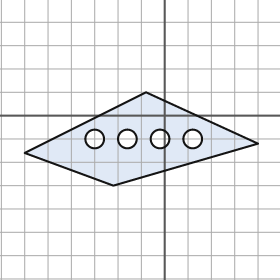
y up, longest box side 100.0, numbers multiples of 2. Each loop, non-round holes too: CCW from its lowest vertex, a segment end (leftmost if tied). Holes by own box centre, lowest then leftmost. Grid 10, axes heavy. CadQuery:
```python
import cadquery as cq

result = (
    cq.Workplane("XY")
    .moveTo(-22.0, -30.0)
    .lineTo(40.0, -12.0)
    .lineTo(-8.0, 10.0)
    .lineTo(-60.0, -16.0)
    .close()
    .moveTo(-30.0, -10.0)
    .circle(4.0)
    .moveTo(-16.0, -10.0)
    .circle(4.0)
    .moveTo(-2.0, -10.0)
    .circle(4.0)
    .moveTo(12.0, -10.0)
    .circle(4.0)
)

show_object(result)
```